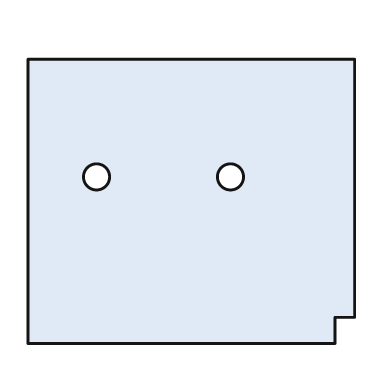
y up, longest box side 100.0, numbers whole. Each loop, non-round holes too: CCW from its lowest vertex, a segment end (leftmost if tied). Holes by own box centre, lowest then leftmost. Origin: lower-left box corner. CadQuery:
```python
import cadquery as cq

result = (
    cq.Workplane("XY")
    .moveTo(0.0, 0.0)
    .lineTo(94.0, 0.0)
    .lineTo(94.0, 8.0)
    .lineTo(100.0, 8.0)
    .lineTo(100.0, 87.0)
    .lineTo(0.0, 87.0)
    .close()
    .moveTo(21.0, 51.0)
    .circle(4.0)
    .moveTo(62.0, 51.0)
    .circle(4.0)
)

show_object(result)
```